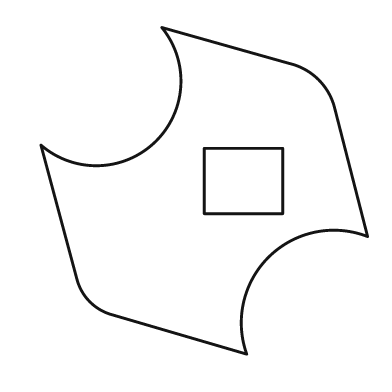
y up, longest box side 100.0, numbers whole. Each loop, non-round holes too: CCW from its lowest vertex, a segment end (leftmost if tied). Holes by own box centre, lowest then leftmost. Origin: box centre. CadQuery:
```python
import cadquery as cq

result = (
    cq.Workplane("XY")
    .moveTo(13.0, -50.0)
    .threePointArc((20.0, -20.0), (50.0, -14.0))
    .lineTo(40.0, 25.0)
    .threePointArc((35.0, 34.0), (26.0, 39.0))
    .lineTo(-13.0, 50.0)
    .threePointArc((-15.0, 15.0), (-50.0, 14.0))
    .lineTo(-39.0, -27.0)
    .threePointArc((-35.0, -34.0), (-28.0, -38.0))
    .close()
    .moveTo(0.0, -7.0)
    .lineTo(24.0, -7.0)
    .lineTo(24.0, 13.0)
    .lineTo(0.0, 13.0)
    .close()
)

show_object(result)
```